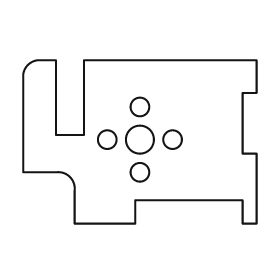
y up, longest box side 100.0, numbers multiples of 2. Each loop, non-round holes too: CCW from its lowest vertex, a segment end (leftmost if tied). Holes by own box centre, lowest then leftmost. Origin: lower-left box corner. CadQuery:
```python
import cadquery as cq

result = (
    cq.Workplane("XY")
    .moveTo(22.0, 0.0)
    .lineTo(48.0, 0.0)
    .lineTo(48.0, 10.0)
    .lineTo(94.0, 10.0)
    .lineTo(94.0, 0.0)
    .lineTo(100.0, 0.0)
    .lineTo(100.0, 30.0)
    .lineTo(94.0, 30.0)
    .lineTo(94.0, 56.0)
    .lineTo(100.0, 56.0)
    .lineTo(100.0, 70.0)
    .lineTo(26.0, 70.0)
    .lineTo(26.0, 38.0)
    .lineTo(14.0, 38.0)
    .lineTo(14.0, 70.0)
    .lineTo(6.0, 70.0)
    .threePointArc((2.0, 68.0), (0.0, 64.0))
    .lineTo(0.0, 22.0)
    .lineTo(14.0, 22.0)
    .threePointArc((20.0, 20.0), (22.0, 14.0))
    .close()
    .moveTo(50.0, 22.0)
    .circle(4.0)
    .moveTo(36.0, 36.0)
    .circle(4.0)
    .moveTo(50.0, 36.0)
    .circle(6.0)
    .moveTo(64.0, 36.0)
    .circle(4.0)
    .moveTo(50.0, 50.0)
    .circle(4.0)
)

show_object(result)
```